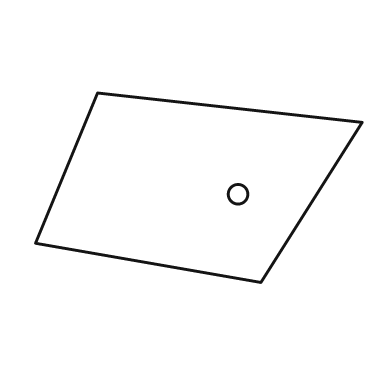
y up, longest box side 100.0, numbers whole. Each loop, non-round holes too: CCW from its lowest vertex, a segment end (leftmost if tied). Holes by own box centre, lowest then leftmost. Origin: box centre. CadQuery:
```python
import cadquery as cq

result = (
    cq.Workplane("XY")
    .moveTo(19.0, -29.0)
    .lineTo(50.0, 20.0)
    .lineTo(-31.0, 29.0)
    .lineTo(-50.0, -17.0)
    .close()
    .moveTo(12.0, -2.0)
    .circle(3.0)
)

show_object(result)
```